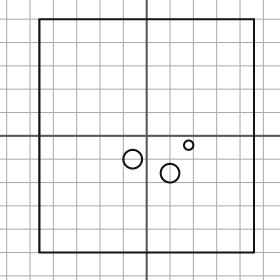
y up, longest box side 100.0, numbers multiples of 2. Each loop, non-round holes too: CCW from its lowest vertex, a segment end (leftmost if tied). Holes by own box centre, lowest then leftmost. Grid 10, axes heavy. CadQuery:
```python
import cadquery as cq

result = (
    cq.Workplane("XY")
    .moveTo(-46.0, -50.0)
    .lineTo(46.0, -50.0)
    .lineTo(46.0, 50.0)
    .lineTo(-46.0, 50.0)
    .close()
    .moveTo(10.0, -16.0)
    .circle(4.0)
    .moveTo(-6.0, -10.0)
    .circle(4.0)
    .moveTo(18.0, -4.0)
    .circle(2.0)
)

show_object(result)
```